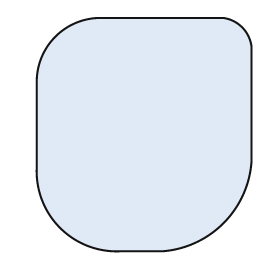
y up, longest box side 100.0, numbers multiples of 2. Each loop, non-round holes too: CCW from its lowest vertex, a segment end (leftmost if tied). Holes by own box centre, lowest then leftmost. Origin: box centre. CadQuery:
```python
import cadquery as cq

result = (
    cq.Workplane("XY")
    .moveTo(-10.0, -50.0)
    .lineTo(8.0, -50.0)
    .threePointArc((34.0, -38.0), (46.0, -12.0))
    .lineTo(46.0, 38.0)
    .threePointArc((42.0, 46.0), (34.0, 50.0))
    .lineTo(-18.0, 50.0)
    .threePointArc((-38.0, 42.0), (-46.0, 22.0))
    .lineTo(-46.0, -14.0)
    .threePointArc((-36.0, -40.0), (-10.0, -50.0))
    .close()
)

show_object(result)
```